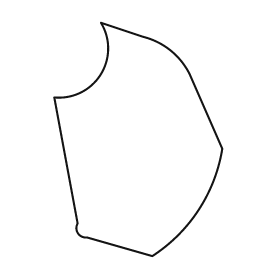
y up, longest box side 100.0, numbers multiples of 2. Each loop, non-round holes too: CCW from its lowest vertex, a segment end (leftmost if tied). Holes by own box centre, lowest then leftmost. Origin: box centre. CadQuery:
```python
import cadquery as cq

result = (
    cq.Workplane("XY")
    .moveTo(6.0, -50.0)
    .threePointArc((26.0, -30.0), (36.0, -4.0))
    .lineTo(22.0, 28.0)
    .threePointArc((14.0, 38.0), (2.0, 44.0))
    .lineTo(-16.0, 50.0)
    .threePointArc((-16.0, 28.0), (-36.0, 18.0))
    .lineTo(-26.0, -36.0)
    .threePointArc((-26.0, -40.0), (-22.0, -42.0))
    .close()
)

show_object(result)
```